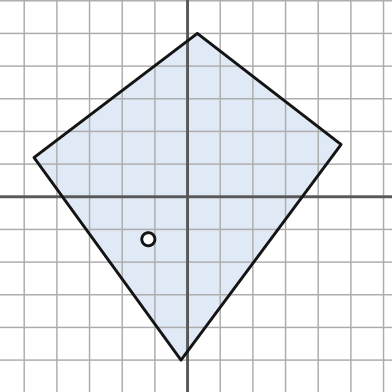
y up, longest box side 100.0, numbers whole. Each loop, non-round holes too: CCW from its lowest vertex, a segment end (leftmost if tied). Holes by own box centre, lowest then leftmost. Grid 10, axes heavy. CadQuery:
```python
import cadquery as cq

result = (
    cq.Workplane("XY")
    .moveTo(-2.0, -50.0)
    .lineTo(47.0, 16.0)
    .lineTo(3.0, 50.0)
    .lineTo(-47.0, 12.0)
    .close()
    .moveTo(-12.0, -13.0)
    .circle(2.0)
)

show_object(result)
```